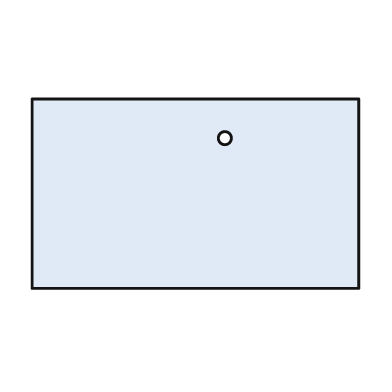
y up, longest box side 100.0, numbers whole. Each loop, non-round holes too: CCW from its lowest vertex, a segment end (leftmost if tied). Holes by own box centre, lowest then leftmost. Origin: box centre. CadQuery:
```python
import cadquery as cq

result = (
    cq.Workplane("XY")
    .moveTo(-50.0, -29.0)
    .lineTo(50.0, -29.0)
    .lineTo(50.0, 29.0)
    .lineTo(-50.0, 29.0)
    .close()
    .moveTo(9.0, 17.0)
    .circle(2.0)
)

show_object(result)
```